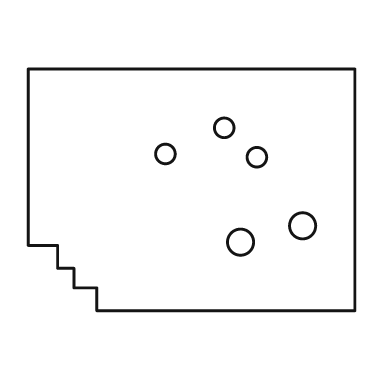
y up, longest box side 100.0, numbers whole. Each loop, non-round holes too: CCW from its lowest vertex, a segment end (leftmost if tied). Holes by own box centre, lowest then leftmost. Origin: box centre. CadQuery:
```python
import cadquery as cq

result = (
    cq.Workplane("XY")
    .moveTo(-29.0, -37.0)
    .lineTo(50.0, -37.0)
    .lineTo(50.0, 37.0)
    .lineTo(-50.0, 37.0)
    .lineTo(-50.0, -17.0)
    .lineTo(-41.0, -17.0)
    .lineTo(-41.0, -24.0)
    .lineTo(-36.0, -24.0)
    .lineTo(-36.0, -30.0)
    .lineTo(-29.0, -30.0)
    .close()
    .moveTo(15.0, -16.0)
    .circle(4.0)
    .moveTo(34.0, -11.0)
    .circle(4.0)
    .moveTo(20.0, 10.0)
    .circle(3.0)
    .moveTo(-8.0, 11.0)
    .circle(3.0)
    .moveTo(10.0, 19.0)
    .circle(3.0)
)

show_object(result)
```